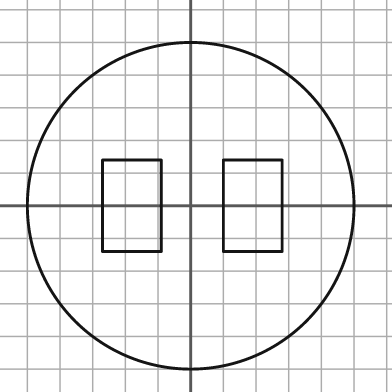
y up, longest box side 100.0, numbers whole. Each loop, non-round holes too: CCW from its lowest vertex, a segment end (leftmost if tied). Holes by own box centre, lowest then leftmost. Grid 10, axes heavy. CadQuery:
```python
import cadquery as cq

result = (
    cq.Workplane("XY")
    .moveTo(0.0, 0.0)
    .circle(50.0)
    .moveTo(-27.0, -14.0)
    .lineTo(-9.0, -14.0)
    .lineTo(-9.0, 14.0)
    .lineTo(-27.0, 14.0)
    .close()
    .moveTo(10.0, -14.0)
    .lineTo(28.0, -14.0)
    .lineTo(28.0, 14.0)
    .lineTo(10.0, 14.0)
    .close()
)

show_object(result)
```